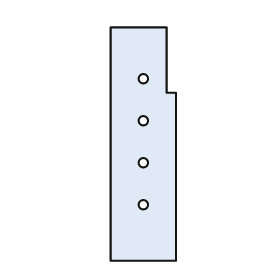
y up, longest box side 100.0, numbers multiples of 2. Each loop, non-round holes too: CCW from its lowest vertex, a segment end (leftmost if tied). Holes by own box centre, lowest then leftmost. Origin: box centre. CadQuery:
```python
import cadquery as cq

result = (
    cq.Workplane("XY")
    .moveTo(-14.0, -50.0)
    .lineTo(14.0, -50.0)
    .lineTo(14.0, 22.0)
    .lineTo(10.0, 22.0)
    .lineTo(10.0, 50.0)
    .lineTo(-14.0, 50.0)
    .close()
    .moveTo(0.0, -26.0)
    .circle(2.0)
    .moveTo(0.0, -8.0)
    .circle(2.0)
    .moveTo(0.0, 10.0)
    .circle(2.0)
    .moveTo(0.0, 28.0)
    .circle(2.0)
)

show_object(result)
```